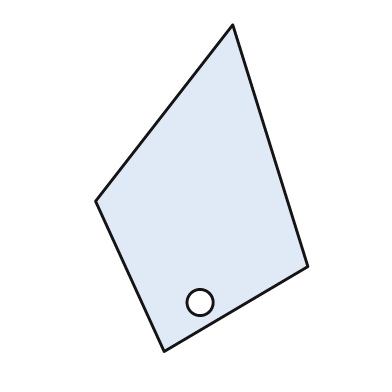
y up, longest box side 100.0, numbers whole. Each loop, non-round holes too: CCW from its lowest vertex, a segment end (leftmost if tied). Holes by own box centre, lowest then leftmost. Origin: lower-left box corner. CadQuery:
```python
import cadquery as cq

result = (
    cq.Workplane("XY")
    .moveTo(21.0, 0.0)
    .lineTo(65.0, 26.0)
    .lineTo(42.0, 100.0)
    .lineTo(0.0, 46.0)
    .close()
    .moveTo(32.0, 15.0)
    .circle(4.0)
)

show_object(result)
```